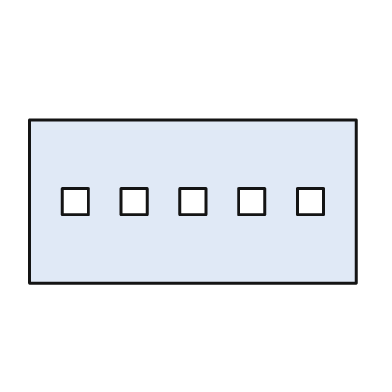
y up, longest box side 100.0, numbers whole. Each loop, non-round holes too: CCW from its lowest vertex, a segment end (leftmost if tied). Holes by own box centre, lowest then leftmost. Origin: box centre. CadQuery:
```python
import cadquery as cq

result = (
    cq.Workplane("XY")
    .moveTo(-50.0, -25.0)
    .lineTo(50.0, -25.0)
    .lineTo(50.0, 25.0)
    .lineTo(-50.0, 25.0)
    .close()
    .moveTo(-40.0, -4.0)
    .lineTo(-32.0, -4.0)
    .lineTo(-32.0, 4.0)
    .lineTo(-40.0, 4.0)
    .close()
    .moveTo(-22.0, -4.0)
    .lineTo(-14.0, -4.0)
    .lineTo(-14.0, 4.0)
    .lineTo(-22.0, 4.0)
    .close()
    .moveTo(-4.0, -4.0)
    .lineTo(4.0, -4.0)
    .lineTo(4.0, 4.0)
    .lineTo(-4.0, 4.0)
    .close()
    .moveTo(14.0, -4.0)
    .lineTo(22.0, -4.0)
    .lineTo(22.0, 4.0)
    .lineTo(14.0, 4.0)
    .close()
    .moveTo(32.0, -4.0)
    .lineTo(40.0, -4.0)
    .lineTo(40.0, 4.0)
    .lineTo(32.0, 4.0)
    .close()
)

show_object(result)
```